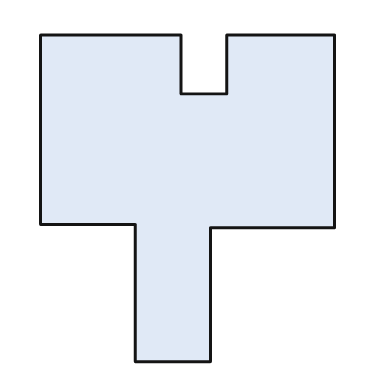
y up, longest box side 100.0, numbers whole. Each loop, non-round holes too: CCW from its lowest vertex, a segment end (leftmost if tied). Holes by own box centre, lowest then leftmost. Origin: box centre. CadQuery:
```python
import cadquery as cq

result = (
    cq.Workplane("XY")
    .moveTo(-16.0, -50.0)
    .lineTo(7.0, -50.0)
    .lineTo(7.0, -9.0)
    .lineTo(45.0, -9.0)
    .lineTo(45.0, 50.0)
    .lineTo(12.0, 50.0)
    .lineTo(12.0, 32.0)
    .lineTo(-2.0, 32.0)
    .lineTo(-2.0, 50.0)
    .lineTo(-45.0, 50.0)
    .lineTo(-45.0, -8.0)
    .lineTo(-16.0, -8.0)
    .close()
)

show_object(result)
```